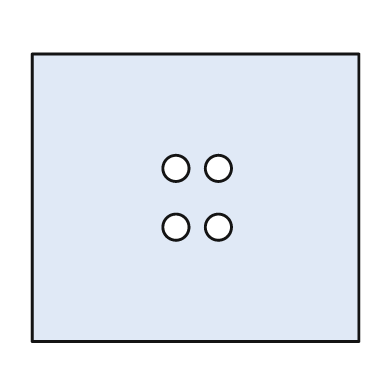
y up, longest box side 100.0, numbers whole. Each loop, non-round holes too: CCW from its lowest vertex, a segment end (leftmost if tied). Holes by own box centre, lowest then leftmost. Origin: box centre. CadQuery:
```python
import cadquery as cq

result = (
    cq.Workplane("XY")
    .moveTo(-50.0, -44.0)
    .lineTo(50.0, -44.0)
    .lineTo(50.0, 44.0)
    .lineTo(-50.0, 44.0)
    .close()
    .moveTo(-6.0, -9.0)
    .circle(4.0)
    .moveTo(7.0, -9.0)
    .circle(4.0)
    .moveTo(-6.0, 9.0)
    .circle(4.0)
    .moveTo(7.0, 9.0)
    .circle(4.0)
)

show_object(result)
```